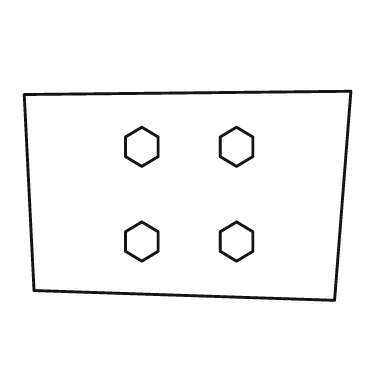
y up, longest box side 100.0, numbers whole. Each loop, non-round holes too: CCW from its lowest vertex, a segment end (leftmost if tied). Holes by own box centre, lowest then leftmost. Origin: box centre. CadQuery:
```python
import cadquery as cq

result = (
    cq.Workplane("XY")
    .moveTo(45.0, -32.0)
    .lineTo(50.0, 32.0)
    .lineTo(-50.0, 31.0)
    .lineTo(-47.0, -29.0)
    .close()
    .moveTo(-14.0, -20.0)
    .lineTo(-9.0, -17.0)
    .lineTo(-9.0, -11.0)
    .lineTo(-14.0, -8.0)
    .lineTo(-19.0, -11.0)
    .lineTo(-19.0, -17.0)
    .close()
    .moveTo(15.0, -20.0)
    .lineTo(20.0, -17.0)
    .lineTo(20.0, -11.0)
    .lineTo(15.0, -8.0)
    .lineTo(10.0, -11.0)
    .lineTo(10.0, -17.0)
    .close()
    .moveTo(-14.0, 9.0)
    .lineTo(-9.0, 12.0)
    .lineTo(-9.0, 18.0)
    .lineTo(-14.0, 21.0)
    .lineTo(-19.0, 18.0)
    .lineTo(-19.0, 12.0)
    .close()
    .moveTo(15.0, 9.0)
    .lineTo(20.0, 12.0)
    .lineTo(20.0, 18.0)
    .lineTo(15.0, 21.0)
    .lineTo(10.0, 18.0)
    .lineTo(10.0, 12.0)
    .close()
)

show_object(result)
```